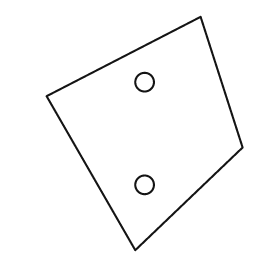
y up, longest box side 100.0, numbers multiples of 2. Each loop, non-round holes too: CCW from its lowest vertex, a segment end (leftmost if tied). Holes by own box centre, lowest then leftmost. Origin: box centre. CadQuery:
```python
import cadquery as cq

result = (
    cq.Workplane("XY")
    .moveTo(-4.0, -50.0)
    .lineTo(42.0, -6.0)
    .lineTo(24.0, 50.0)
    .lineTo(-42.0, 16.0)
    .close()
    .moveTo(0.0, -22.0)
    .circle(4.0)
    .moveTo(0.0, 22.0)
    .circle(4.0)
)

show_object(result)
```